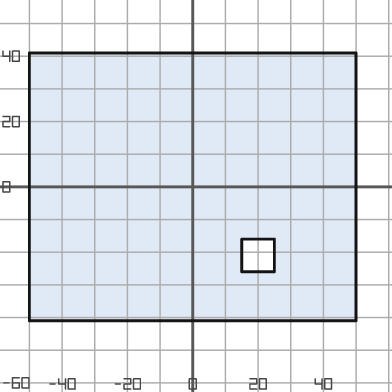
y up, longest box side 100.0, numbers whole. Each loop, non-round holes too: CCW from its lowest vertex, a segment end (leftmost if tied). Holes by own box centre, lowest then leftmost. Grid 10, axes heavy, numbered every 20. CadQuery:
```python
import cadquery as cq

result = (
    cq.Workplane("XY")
    .moveTo(-50.0, -41.0)
    .lineTo(50.0, -41.0)
    .lineTo(50.0, 41.0)
    .lineTo(-50.0, 41.0)
    .close()
    .moveTo(15.0, -26.0)
    .lineTo(25.0, -26.0)
    .lineTo(25.0, -16.0)
    .lineTo(15.0, -16.0)
    .close()
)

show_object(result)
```